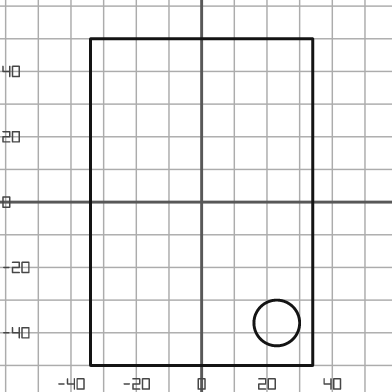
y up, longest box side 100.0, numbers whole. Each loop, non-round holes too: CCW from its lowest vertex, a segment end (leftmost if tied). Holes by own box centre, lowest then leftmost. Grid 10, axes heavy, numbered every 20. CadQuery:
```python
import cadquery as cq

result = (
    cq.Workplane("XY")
    .moveTo(-34.0, -50.0)
    .lineTo(34.0, -50.0)
    .lineTo(34.0, 50.0)
    .lineTo(-34.0, 50.0)
    .close()
    .moveTo(23.0, -37.0)
    .circle(7.0)
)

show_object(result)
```